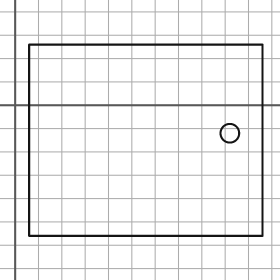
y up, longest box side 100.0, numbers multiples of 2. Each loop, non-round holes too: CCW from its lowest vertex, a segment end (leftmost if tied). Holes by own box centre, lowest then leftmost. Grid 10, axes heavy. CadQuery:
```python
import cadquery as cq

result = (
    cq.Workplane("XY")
    .moveTo(6.0, -56.0)
    .lineTo(106.0, -56.0)
    .lineTo(106.0, 26.0)
    .lineTo(6.0, 26.0)
    .close()
    .moveTo(92.0, -12.0)
    .circle(4.0)
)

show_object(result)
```